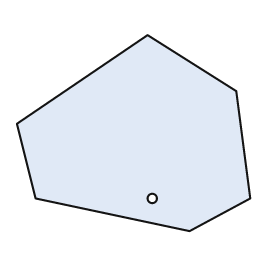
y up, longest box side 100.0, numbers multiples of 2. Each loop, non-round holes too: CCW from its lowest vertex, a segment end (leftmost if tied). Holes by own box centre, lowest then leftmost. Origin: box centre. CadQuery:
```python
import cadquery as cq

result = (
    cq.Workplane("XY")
    .moveTo(24.0, -42.0)
    .lineTo(50.0, -28.0)
    .lineTo(44.0, 18.0)
    .lineTo(6.0, 42.0)
    .lineTo(-50.0, 4.0)
    .lineTo(-42.0, -28.0)
    .close()
    .moveTo(8.0, -28.0)
    .circle(2.0)
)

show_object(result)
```